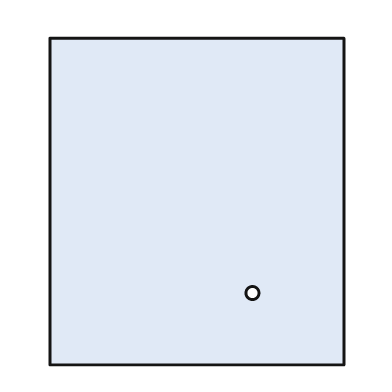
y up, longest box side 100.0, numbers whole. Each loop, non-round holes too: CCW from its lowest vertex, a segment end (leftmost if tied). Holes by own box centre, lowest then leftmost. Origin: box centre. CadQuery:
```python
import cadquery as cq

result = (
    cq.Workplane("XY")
    .moveTo(-45.0, -50.0)
    .lineTo(45.0, -50.0)
    .lineTo(45.0, 50.0)
    .lineTo(-45.0, 50.0)
    .close()
    .moveTo(17.0, -28.0)
    .circle(2.0)
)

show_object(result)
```